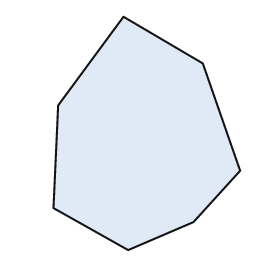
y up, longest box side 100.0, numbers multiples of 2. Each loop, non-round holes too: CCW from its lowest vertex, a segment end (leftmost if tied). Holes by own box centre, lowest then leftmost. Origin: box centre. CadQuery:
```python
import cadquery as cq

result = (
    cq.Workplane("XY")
    .moveTo(-8.0, -50.0)
    .lineTo(20.0, -38.0)
    .lineTo(40.0, -16.0)
    .lineTo(24.0, 30.0)
    .lineTo(-10.0, 50.0)
    .lineTo(-38.0, 12.0)
    .lineTo(-40.0, -32.0)
    .close()
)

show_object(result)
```